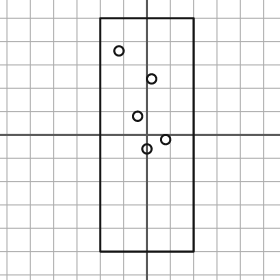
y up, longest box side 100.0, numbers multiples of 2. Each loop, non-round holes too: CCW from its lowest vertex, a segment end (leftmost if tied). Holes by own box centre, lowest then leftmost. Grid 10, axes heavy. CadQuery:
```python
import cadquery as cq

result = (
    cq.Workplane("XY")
    .moveTo(-20.0, -50.0)
    .lineTo(20.0, -50.0)
    .lineTo(20.0, 50.0)
    .lineTo(-20.0, 50.0)
    .close()
    .moveTo(0.0, -6.0)
    .circle(2.0)
    .moveTo(8.0, -2.0)
    .circle(2.0)
    .moveTo(-4.0, 8.0)
    .circle(2.0)
    .moveTo(2.0, 24.0)
    .circle(2.0)
    .moveTo(-12.0, 36.0)
    .circle(2.0)
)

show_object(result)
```